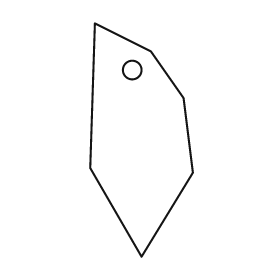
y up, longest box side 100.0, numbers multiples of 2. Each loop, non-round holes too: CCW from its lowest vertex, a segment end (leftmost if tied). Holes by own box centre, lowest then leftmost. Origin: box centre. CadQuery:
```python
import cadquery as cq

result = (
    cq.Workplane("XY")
    .moveTo(0.0, -50.0)
    .lineTo(22.0, -14.0)
    .lineTo(18.0, 18.0)
    .lineTo(4.0, 38.0)
    .lineTo(-20.0, 50.0)
    .lineTo(-22.0, -12.0)
    .close()
    .moveTo(-4.0, 30.0)
    .circle(4.0)
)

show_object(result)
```